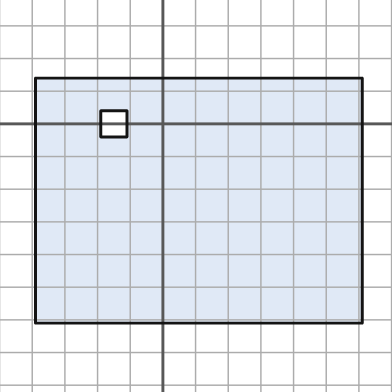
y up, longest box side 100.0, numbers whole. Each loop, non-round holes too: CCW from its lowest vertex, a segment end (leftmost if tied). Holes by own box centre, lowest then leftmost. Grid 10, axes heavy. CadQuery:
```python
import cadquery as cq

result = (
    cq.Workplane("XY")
    .moveTo(-39.0, -61.0)
    .lineTo(61.0, -61.0)
    .lineTo(61.0, 14.0)
    .lineTo(-39.0, 14.0)
    .close()
    .moveTo(-19.0, -4.0)
    .lineTo(-11.0, -4.0)
    .lineTo(-11.0, 4.0)
    .lineTo(-19.0, 4.0)
    .close()
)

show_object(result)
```